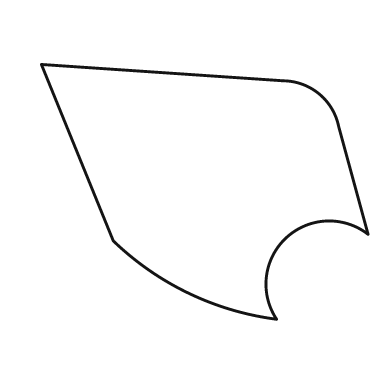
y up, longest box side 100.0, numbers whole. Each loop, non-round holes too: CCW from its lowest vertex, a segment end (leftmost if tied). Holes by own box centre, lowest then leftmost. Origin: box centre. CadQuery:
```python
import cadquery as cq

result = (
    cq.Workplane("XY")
    .moveTo(22.0, -39.0)
    .threePointArc((25.0, -14.0), (50.0, -13.0))
    .lineTo(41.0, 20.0)
    .threePointArc((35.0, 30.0), (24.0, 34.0))
    .lineTo(-50.0, 39.0)
    .lineTo(-28.0, -15.0)
    .threePointArc((-5.0, -31.0), (22.0, -39.0))
    .close()
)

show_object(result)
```